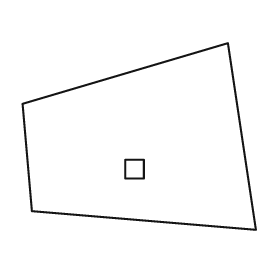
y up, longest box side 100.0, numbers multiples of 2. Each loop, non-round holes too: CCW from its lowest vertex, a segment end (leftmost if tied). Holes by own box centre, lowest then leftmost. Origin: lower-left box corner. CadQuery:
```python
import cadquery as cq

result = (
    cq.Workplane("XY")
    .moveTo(100.0, 0.0)
    .lineTo(88.0, 80.0)
    .lineTo(0.0, 54.0)
    .lineTo(4.0, 8.0)
    .close()
    .moveTo(44.0, 22.0)
    .lineTo(52.0, 22.0)
    .lineTo(52.0, 30.0)
    .lineTo(44.0, 30.0)
    .close()
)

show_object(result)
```